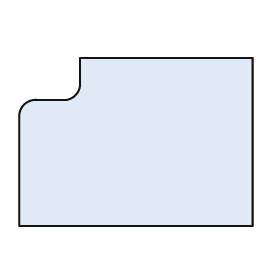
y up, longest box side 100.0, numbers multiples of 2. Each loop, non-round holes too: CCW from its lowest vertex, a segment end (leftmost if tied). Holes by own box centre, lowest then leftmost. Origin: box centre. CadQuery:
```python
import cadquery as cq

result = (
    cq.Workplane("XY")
    .moveTo(-50.0, -36.0)
    .lineTo(50.0, -36.0)
    .lineTo(50.0, 36.0)
    .lineTo(-24.0, 36.0)
    .lineTo(-24.0, 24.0)
    .threePointArc((-26.0, 20.0), (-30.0, 18.0))
    .lineTo(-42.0, 18.0)
    .threePointArc((-48.0, 16.0), (-50.0, 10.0))
    .close()
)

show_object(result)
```